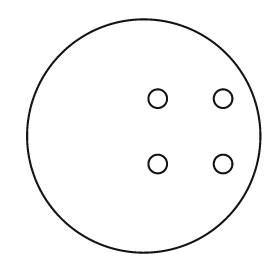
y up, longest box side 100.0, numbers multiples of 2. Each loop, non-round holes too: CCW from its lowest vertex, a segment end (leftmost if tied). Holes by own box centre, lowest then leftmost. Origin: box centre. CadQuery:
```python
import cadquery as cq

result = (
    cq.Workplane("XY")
    .moveTo(0.0, 0.0)
    .circle(50.0)
    .moveTo(6.0, -12.0)
    .circle(4.0)
    .moveTo(34.0, -12.0)
    .circle(4.0)
    .moveTo(6.0, 16.0)
    .circle(4.0)
    .moveTo(34.0, 16.0)
    .circle(4.0)
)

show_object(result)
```